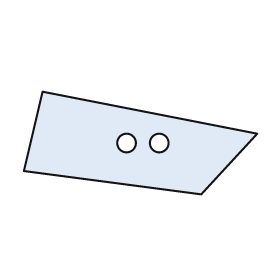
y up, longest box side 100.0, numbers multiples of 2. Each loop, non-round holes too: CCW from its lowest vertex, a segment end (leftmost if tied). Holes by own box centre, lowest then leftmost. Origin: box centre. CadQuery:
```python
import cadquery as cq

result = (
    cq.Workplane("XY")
    .moveTo(26.0, -22.0)
    .lineTo(50.0, 4.0)
    .lineTo(-42.0, 22.0)
    .lineTo(-50.0, -12.0)
    .close()
    .moveTo(-6.0, 0.0)
    .circle(4.0)
    .moveTo(8.0, 0.0)
    .circle(4.0)
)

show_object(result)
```